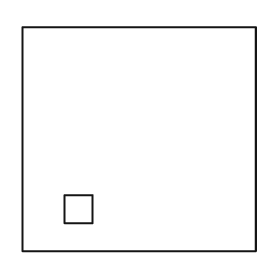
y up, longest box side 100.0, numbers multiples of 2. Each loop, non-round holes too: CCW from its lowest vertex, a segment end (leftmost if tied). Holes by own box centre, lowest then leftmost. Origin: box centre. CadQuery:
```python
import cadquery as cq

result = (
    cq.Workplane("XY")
    .moveTo(-50.0, -48.0)
    .lineTo(50.0, -48.0)
    .lineTo(50.0, 48.0)
    .lineTo(-50.0, 48.0)
    .close()
    .moveTo(-32.0, -36.0)
    .lineTo(-20.0, -36.0)
    .lineTo(-20.0, -24.0)
    .lineTo(-32.0, -24.0)
    .close()
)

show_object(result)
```